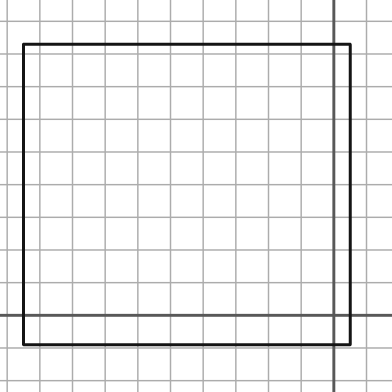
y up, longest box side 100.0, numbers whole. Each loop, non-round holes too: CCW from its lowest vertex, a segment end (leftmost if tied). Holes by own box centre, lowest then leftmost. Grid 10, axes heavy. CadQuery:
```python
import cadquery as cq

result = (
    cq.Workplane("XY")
    .moveTo(-95.0, -9.0)
    .lineTo(5.0, -9.0)
    .lineTo(5.0, 83.0)
    .lineTo(-95.0, 83.0)
    .close()
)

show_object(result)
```